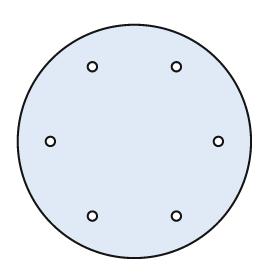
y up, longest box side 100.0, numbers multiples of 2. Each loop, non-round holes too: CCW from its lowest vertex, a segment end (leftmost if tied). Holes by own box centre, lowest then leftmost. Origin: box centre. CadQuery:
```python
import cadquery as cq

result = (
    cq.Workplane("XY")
    .moveTo(0.0, 0.0)
    .circle(50.0)
    .moveTo(-18.0, -32.0)
    .circle(2.0)
    .moveTo(18.0, -32.0)
    .circle(2.0)
    .moveTo(-36.0, 0.0)
    .circle(2.0)
    .moveTo(36.0, 0.0)
    .circle(2.0)
    .moveTo(-18.0, 32.0)
    .circle(2.0)
    .moveTo(18.0, 32.0)
    .circle(2.0)
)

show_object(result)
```